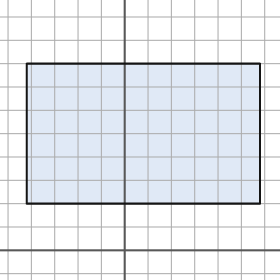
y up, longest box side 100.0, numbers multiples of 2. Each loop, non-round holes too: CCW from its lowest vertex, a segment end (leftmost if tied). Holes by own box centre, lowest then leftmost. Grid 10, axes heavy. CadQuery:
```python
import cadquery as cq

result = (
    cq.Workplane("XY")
    .moveTo(-42.0, 20.0)
    .lineTo(58.0, 20.0)
    .lineTo(58.0, 80.0)
    .lineTo(-42.0, 80.0)
    .close()
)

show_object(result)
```